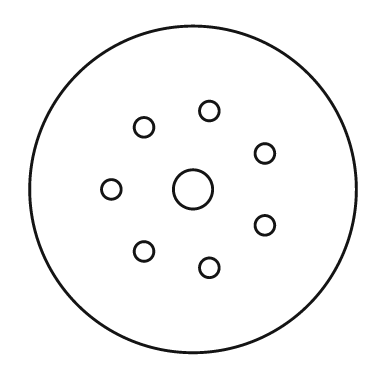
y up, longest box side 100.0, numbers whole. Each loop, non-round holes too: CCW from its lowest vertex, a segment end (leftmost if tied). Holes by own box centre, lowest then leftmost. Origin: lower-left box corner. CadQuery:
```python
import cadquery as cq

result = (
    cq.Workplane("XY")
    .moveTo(50.0, 50.0)
    .circle(50.0)
    .moveTo(55.0, 26.0)
    .circle(3.0)
    .moveTo(35.0, 31.0)
    .circle(3.0)
    .moveTo(72.0, 39.0)
    .circle(3.0)
    .moveTo(25.0, 50.0)
    .circle(3.0)
    .moveTo(50.0, 50.0)
    .circle(6.0)
    .moveTo(72.0, 61.0)
    .circle(3.0)
    .moveTo(35.0, 69.0)
    .circle(3.0)
    .moveTo(55.0, 74.0)
    .circle(3.0)
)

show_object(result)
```